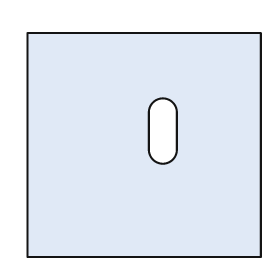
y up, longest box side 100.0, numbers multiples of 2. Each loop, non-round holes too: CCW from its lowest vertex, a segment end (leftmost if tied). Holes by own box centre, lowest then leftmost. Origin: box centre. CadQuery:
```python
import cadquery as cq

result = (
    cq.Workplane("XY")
    .moveTo(-50.0, -48.0)
    .lineTo(50.0, -48.0)
    .lineTo(50.0, 48.0)
    .lineTo(-50.0, 48.0)
    .close()
    .moveTo(2.0, -2.0)
    .threePointArc((8.0, -8.0), (14.0, -2.0))
    .lineTo(14.0, 14.0)
    .threePointArc((8.0, 20.0), (2.0, 14.0))
    .close()
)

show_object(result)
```